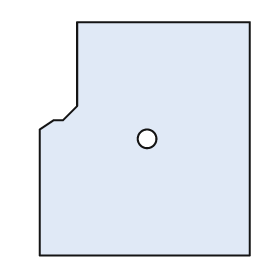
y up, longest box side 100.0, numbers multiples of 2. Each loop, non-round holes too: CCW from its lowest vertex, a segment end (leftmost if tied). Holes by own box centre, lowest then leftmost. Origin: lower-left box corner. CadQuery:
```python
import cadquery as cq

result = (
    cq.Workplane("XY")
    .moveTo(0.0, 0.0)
    .lineTo(90.0, 0.0)
    .lineTo(90.0, 100.0)
    .lineTo(16.0, 100.0)
    .lineTo(16.0, 64.0)
    .lineTo(10.0, 58.0)
    .lineTo(6.0, 58.0)
    .lineTo(0.0, 54.0)
    .close()
    .moveTo(46.0, 50.0)
    .circle(4.0)
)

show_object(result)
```